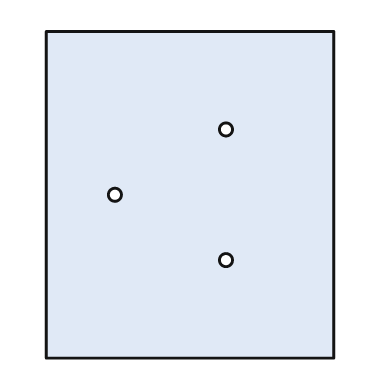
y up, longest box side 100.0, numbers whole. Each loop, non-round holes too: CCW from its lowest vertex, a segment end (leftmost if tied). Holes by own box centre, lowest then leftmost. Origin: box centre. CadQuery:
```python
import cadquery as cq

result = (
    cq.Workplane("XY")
    .moveTo(-44.0, -50.0)
    .lineTo(44.0, -50.0)
    .lineTo(44.0, 50.0)
    .lineTo(-44.0, 50.0)
    .close()
    .moveTo(11.0, -20.0)
    .circle(2.0)
    .moveTo(-23.0, 0.0)
    .circle(2.0)
    .moveTo(11.0, 20.0)
    .circle(2.0)
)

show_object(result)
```